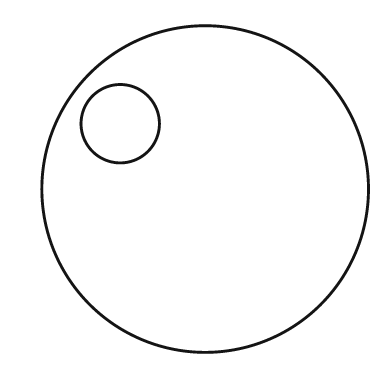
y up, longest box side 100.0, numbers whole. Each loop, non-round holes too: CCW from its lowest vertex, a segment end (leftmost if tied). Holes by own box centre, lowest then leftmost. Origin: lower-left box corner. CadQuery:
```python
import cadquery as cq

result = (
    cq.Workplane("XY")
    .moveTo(50.0, 50.0)
    .circle(50.0)
    .moveTo(24.0, 70.0)
    .circle(12.0)
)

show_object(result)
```